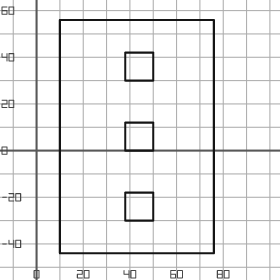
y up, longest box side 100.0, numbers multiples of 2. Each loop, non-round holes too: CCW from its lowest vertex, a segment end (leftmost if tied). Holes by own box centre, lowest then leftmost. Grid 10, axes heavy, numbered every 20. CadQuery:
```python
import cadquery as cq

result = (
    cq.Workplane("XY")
    .moveTo(10.0, -44.0)
    .lineTo(76.0, -44.0)
    .lineTo(76.0, 56.0)
    .lineTo(10.0, 56.0)
    .close()
    .moveTo(38.0, -30.0)
    .lineTo(50.0, -30.0)
    .lineTo(50.0, -18.0)
    .lineTo(38.0, -18.0)
    .close()
    .moveTo(38.0, 0.0)
    .lineTo(50.0, 0.0)
    .lineTo(50.0, 12.0)
    .lineTo(38.0, 12.0)
    .close()
    .moveTo(38.0, 30.0)
    .lineTo(50.0, 30.0)
    .lineTo(50.0, 42.0)
    .lineTo(38.0, 42.0)
    .close()
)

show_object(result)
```